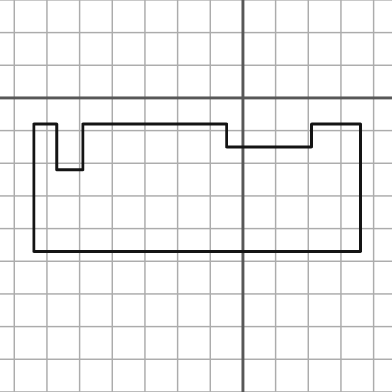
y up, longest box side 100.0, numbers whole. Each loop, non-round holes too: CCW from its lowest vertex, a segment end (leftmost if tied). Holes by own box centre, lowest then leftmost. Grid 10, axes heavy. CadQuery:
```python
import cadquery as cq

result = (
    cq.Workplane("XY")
    .moveTo(-64.0, -47.0)
    .lineTo(36.0, -47.0)
    .lineTo(36.0, -8.0)
    .lineTo(21.0, -8.0)
    .lineTo(21.0, -15.0)
    .lineTo(-5.0, -15.0)
    .lineTo(-5.0, -8.0)
    .lineTo(-49.0, -8.0)
    .lineTo(-49.0, -22.0)
    .lineTo(-57.0, -22.0)
    .lineTo(-57.0, -8.0)
    .lineTo(-64.0, -8.0)
    .close()
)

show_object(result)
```